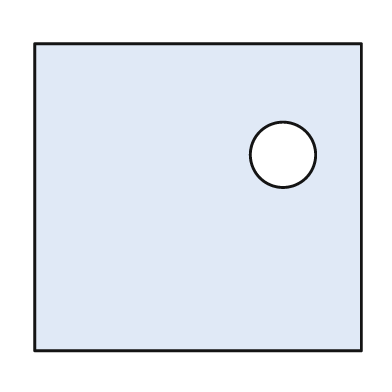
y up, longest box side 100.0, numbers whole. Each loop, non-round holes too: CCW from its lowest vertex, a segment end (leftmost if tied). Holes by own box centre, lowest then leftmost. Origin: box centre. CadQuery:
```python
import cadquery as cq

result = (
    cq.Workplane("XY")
    .moveTo(-50.0, -47.0)
    .lineTo(50.0, -47.0)
    .lineTo(50.0, 47.0)
    .lineTo(-50.0, 47.0)
    .close()
    .moveTo(26.0, 13.0)
    .circle(10.0)
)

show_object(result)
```